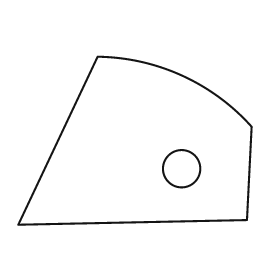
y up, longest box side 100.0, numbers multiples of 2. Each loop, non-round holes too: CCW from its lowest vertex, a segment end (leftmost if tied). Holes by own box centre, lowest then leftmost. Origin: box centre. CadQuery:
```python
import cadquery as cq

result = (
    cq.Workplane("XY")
    .moveTo(-50.0, -36.0)
    .lineTo(48.0, -34.0)
    .lineTo(50.0, 6.0)
    .threePointArc((20.0, 28.0), (-16.0, 36.0))
    .close()
    .moveTo(20.0, -12.0)
    .circle(8.0)
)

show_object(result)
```